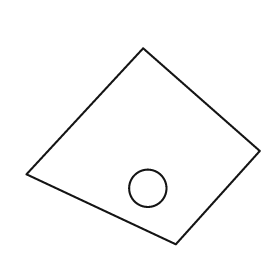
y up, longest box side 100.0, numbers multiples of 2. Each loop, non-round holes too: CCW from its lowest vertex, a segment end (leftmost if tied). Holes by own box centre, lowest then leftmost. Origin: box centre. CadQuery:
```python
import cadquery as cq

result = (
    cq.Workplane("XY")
    .moveTo(14.0, -42.0)
    .lineTo(50.0, -2.0)
    .lineTo(0.0, 42.0)
    .lineTo(-50.0, -12.0)
    .close()
    .moveTo(2.0, -18.0)
    .circle(8.0)
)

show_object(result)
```